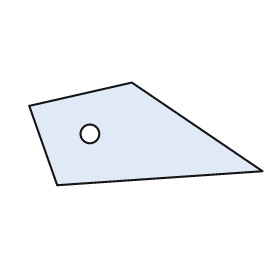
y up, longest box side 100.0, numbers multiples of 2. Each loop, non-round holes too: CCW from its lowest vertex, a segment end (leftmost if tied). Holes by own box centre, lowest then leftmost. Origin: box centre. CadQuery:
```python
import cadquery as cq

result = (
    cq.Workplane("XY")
    .moveTo(-38.0, -22.0)
    .lineTo(50.0, -16.0)
    .lineTo(-6.0, 22.0)
    .lineTo(-50.0, 12.0)
    .close()
    .moveTo(-24.0, 0.0)
    .circle(4.0)
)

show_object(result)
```